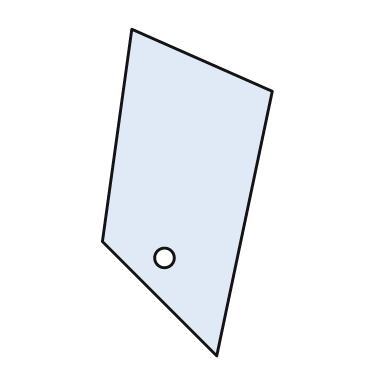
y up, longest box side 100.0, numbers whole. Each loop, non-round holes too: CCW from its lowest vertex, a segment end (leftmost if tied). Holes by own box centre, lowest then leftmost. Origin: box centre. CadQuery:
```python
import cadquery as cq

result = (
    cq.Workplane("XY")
    .moveTo(9.0, -50.0)
    .lineTo(26.0, 31.0)
    .lineTo(-17.0, 50.0)
    .lineTo(-26.0, -15.0)
    .close()
    .moveTo(-7.0, -20.0)
    .circle(3.0)
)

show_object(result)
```